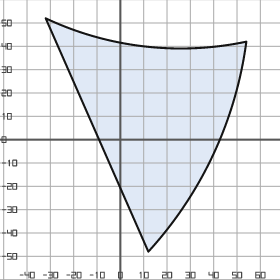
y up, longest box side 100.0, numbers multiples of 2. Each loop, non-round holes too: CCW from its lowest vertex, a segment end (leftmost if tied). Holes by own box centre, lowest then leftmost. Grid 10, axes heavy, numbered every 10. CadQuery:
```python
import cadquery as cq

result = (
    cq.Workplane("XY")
    .moveTo(12.0, -48.0)
    .threePointArc((40.0, -6.0), (54.0, 42.0))
    .threePointArc((10.0, 40.0), (-32.0, 52.0))
    .close()
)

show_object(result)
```